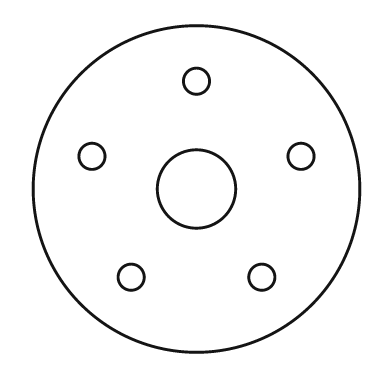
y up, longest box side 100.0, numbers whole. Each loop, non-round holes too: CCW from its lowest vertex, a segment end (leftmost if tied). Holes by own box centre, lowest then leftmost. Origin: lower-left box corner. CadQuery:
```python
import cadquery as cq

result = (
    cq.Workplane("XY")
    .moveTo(50.0, 50.0)
    .circle(50.0)
    .moveTo(30.0, 23.0)
    .circle(4.0)
    .moveTo(70.0, 23.0)
    .circle(4.0)
    .moveTo(50.0, 50.0)
    .circle(12.0)
    .moveTo(18.0, 60.0)
    .circle(4.0)
    .moveTo(82.0, 60.0)
    .circle(4.0)
    .moveTo(50.0, 83.0)
    .circle(4.0)
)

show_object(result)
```